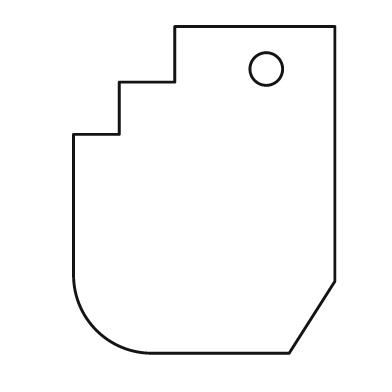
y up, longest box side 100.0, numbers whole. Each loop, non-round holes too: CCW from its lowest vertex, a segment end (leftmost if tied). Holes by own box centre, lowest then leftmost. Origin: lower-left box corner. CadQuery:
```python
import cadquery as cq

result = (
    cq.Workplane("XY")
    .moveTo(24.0, 0.0)
    .lineTo(66.0, 0.0)
    .lineTo(80.0, 22.0)
    .lineTo(80.0, 100.0)
    .lineTo(31.0, 100.0)
    .lineTo(31.0, 83.0)
    .lineTo(14.0, 83.0)
    .lineTo(14.0, 67.0)
    .lineTo(0.0, 67.0)
    .lineTo(0.0, 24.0)
    .threePointArc((7.0, 7.0), (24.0, 0.0))
    .close()
    .moveTo(59.0, 87.0)
    .circle(5.0)
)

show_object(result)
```